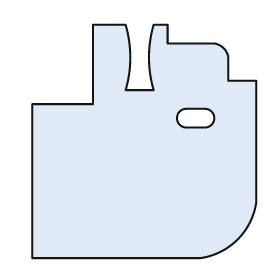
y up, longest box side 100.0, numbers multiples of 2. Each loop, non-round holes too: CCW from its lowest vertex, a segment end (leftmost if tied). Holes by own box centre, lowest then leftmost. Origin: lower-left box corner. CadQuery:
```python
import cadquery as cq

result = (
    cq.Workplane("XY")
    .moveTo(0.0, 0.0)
    .lineTo(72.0, 0.0)
    .threePointArc((88.0, 8.0), (96.0, 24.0))
    .lineTo(96.0, 76.0)
    .lineTo(84.0, 76.0)
    .lineTo(84.0, 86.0)
    .threePointArc((82.0, 90.0), (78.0, 92.0))
    .lineTo(58.0, 92.0)
    .lineTo(58.0, 100.0)
    .lineTo(52.0, 100.0)
    .threePointArc((50.0, 86.0), (52.0, 72.0))
    .lineTo(40.0, 72.0)
    .threePointArc((42.0, 86.0), (40.0, 100.0))
    .lineTo(26.0, 100.0)
    .lineTo(26.0, 66.0)
    .lineTo(0.0, 66.0)
    .close()
    .moveTo(66.0, 56.0)
    .lineTo(74.0, 56.0)
    .threePointArc((78.0, 60.0), (74.0, 64.0))
    .lineTo(66.0, 64.0)
    .threePointArc((62.0, 60.0), (66.0, 56.0))
    .close()
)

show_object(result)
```